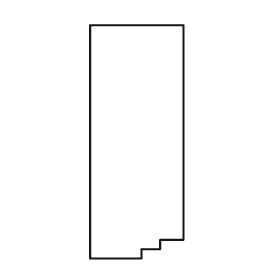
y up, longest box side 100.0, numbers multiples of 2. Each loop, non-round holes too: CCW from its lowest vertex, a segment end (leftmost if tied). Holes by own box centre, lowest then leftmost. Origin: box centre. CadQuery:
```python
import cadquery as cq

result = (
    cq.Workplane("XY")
    .moveTo(-20.0, -50.0)
    .lineTo(2.0, -50.0)
    .lineTo(2.0, -46.0)
    .lineTo(10.0, -46.0)
    .lineTo(10.0, -42.0)
    .lineTo(20.0, -42.0)
    .lineTo(20.0, 50.0)
    .lineTo(-20.0, 50.0)
    .close()
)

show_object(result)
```